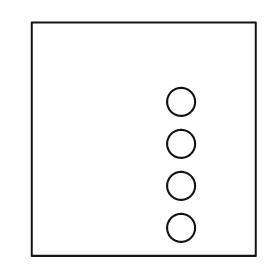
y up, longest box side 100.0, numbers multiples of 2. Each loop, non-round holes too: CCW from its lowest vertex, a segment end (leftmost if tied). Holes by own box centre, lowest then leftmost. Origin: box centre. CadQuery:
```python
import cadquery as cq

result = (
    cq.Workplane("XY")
    .moveTo(-48.0, -50.0)
    .lineTo(48.0, -50.0)
    .lineTo(48.0, 50.0)
    .lineTo(-48.0, 50.0)
    .close()
    .moveTo(16.0, -38.0)
    .circle(6.0)
    .moveTo(16.0, -20.0)
    .circle(6.0)
    .moveTo(16.0, -2.0)
    .circle(6.0)
    .moveTo(16.0, 16.0)
    .circle(6.0)
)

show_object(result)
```